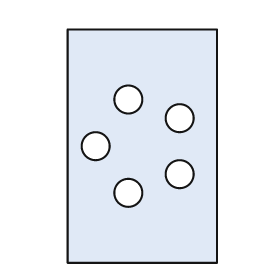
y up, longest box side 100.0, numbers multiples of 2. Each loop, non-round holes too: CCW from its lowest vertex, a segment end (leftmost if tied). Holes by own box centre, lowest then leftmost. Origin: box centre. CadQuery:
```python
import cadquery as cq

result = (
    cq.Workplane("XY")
    .moveTo(-32.0, -50.0)
    .lineTo(32.0, -50.0)
    .lineTo(32.0, 50.0)
    .lineTo(-32.0, 50.0)
    .close()
    .moveTo(-6.0, -20.0)
    .circle(6.0)
    .moveTo(16.0, -12.0)
    .circle(6.0)
    .moveTo(-20.0, 0.0)
    .circle(6.0)
    .moveTo(16.0, 12.0)
    .circle(6.0)
    .moveTo(-6.0, 20.0)
    .circle(6.0)
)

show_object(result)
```